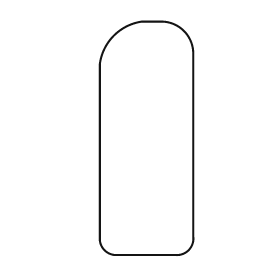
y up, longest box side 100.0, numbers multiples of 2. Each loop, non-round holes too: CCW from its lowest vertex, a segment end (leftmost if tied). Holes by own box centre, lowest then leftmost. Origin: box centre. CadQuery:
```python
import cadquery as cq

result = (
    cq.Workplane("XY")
    .moveTo(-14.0, -50.0)
    .lineTo(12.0, -50.0)
    .threePointArc((18.0, -48.0), (20.0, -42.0))
    .lineTo(20.0, 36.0)
    .threePointArc((16.0, 46.0), (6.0, 50.0))
    .lineTo(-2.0, 50.0)
    .threePointArc((-14.0, 44.0), (-20.0, 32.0))
    .lineTo(-20.0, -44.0)
    .threePointArc((-18.0, -48.0), (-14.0, -50.0))
    .close()
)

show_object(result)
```